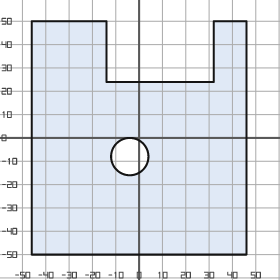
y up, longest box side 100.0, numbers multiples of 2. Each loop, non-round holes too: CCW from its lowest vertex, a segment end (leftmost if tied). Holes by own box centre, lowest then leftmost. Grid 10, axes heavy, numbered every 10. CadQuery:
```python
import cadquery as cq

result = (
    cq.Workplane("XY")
    .moveTo(-46.0, -50.0)
    .lineTo(46.0, -50.0)
    .lineTo(46.0, 50.0)
    .lineTo(32.0, 50.0)
    .lineTo(32.0, 24.0)
    .lineTo(-14.0, 24.0)
    .lineTo(-14.0, 50.0)
    .lineTo(-46.0, 50.0)
    .close()
    .moveTo(-4.0, -8.0)
    .circle(8.0)
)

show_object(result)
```